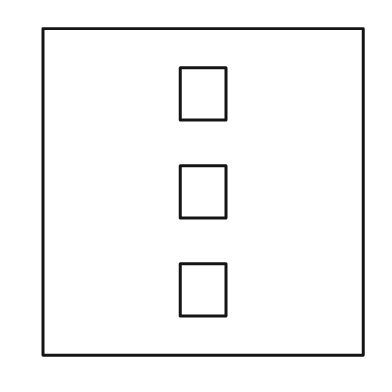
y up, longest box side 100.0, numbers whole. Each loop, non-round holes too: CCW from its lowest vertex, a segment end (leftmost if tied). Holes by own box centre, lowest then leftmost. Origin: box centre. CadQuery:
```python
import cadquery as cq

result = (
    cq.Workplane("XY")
    .moveTo(-49.0, -50.0)
    .lineTo(49.0, -50.0)
    .lineTo(49.0, 50.0)
    .lineTo(-49.0, 50.0)
    .close()
    .moveTo(-7.0, -38.0)
    .lineTo(7.0, -38.0)
    .lineTo(7.0, -22.0)
    .lineTo(-7.0, -22.0)
    .close()
    .moveTo(-7.0, -8.0)
    .lineTo(7.0, -8.0)
    .lineTo(7.0, 8.0)
    .lineTo(-7.0, 8.0)
    .close()
    .moveTo(-7.0, 22.0)
    .lineTo(7.0, 22.0)
    .lineTo(7.0, 38.0)
    .lineTo(-7.0, 38.0)
    .close()
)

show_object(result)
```